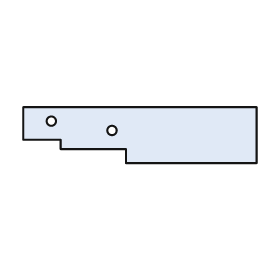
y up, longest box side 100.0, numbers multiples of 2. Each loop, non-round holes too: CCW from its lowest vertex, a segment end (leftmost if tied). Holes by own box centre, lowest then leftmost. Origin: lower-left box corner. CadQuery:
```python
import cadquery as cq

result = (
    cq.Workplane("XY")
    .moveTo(44.0, 0.0)
    .lineTo(100.0, 0.0)
    .lineTo(100.0, 24.0)
    .lineTo(0.0, 24.0)
    .lineTo(0.0, 10.0)
    .lineTo(16.0, 10.0)
    .lineTo(16.0, 6.0)
    .lineTo(44.0, 6.0)
    .close()
    .moveTo(38.0, 14.0)
    .circle(2.0)
    .moveTo(12.0, 18.0)
    .circle(2.0)
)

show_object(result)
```